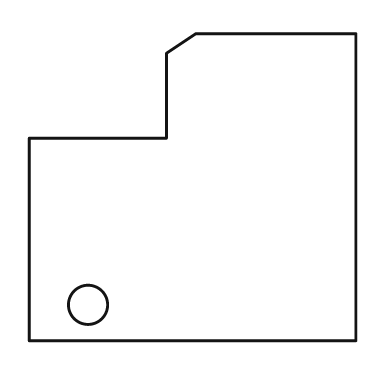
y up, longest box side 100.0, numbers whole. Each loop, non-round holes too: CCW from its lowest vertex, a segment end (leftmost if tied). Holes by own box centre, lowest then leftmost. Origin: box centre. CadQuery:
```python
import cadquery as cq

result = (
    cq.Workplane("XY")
    .moveTo(-50.0, -47.0)
    .lineTo(50.0, -47.0)
    .lineTo(50.0, 47.0)
    .lineTo(1.0, 47.0)
    .lineTo(-8.0, 41.0)
    .lineTo(-8.0, 15.0)
    .lineTo(-50.0, 15.0)
    .close()
    .moveTo(-32.0, -36.0)
    .circle(6.0)
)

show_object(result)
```